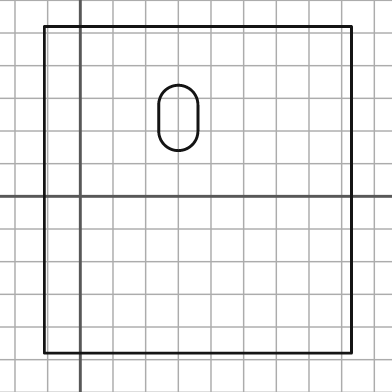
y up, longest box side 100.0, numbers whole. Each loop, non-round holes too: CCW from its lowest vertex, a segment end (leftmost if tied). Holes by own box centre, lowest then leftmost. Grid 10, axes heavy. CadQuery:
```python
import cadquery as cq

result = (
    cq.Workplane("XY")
    .moveTo(-11.0, -48.0)
    .lineTo(83.0, -48.0)
    .lineTo(83.0, 52.0)
    .lineTo(-11.0, 52.0)
    .close()
    .moveTo(24.0, 20.0)
    .threePointArc((30.0, 14.0), (36.0, 20.0))
    .lineTo(36.0, 28.0)
    .threePointArc((30.0, 34.0), (24.0, 28.0))
    .close()
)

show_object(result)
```